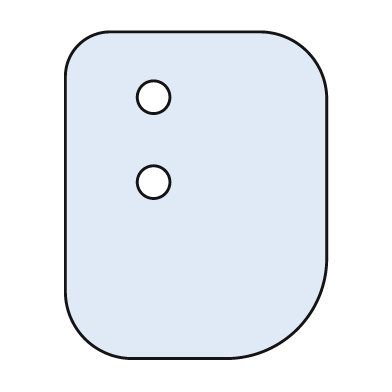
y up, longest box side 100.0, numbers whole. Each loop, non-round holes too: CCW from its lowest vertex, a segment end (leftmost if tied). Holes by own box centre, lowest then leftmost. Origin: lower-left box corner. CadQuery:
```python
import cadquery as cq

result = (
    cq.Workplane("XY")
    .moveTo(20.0, 0.0)
    .lineTo(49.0, 0.0)
    .threePointArc((71.0, 9.0), (80.0, 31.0))
    .lineTo(80.0, 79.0)
    .threePointArc((74.0, 94.0), (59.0, 100.0))
    .lineTo(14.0, 100.0)
    .threePointArc((4.0, 96.0), (0.0, 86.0))
    .lineTo(0.0, 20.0)
    .threePointArc((6.0, 6.0), (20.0, 0.0))
    .close()
    .moveTo(27.0, 54.0)
    .circle(5.0)
    .moveTo(27.0, 80.0)
    .circle(5.0)
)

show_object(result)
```